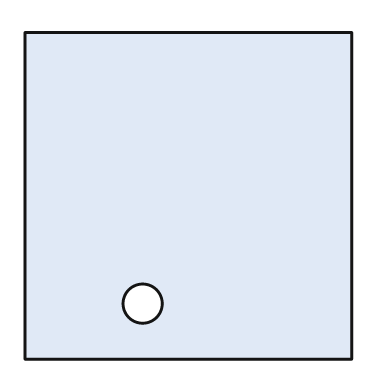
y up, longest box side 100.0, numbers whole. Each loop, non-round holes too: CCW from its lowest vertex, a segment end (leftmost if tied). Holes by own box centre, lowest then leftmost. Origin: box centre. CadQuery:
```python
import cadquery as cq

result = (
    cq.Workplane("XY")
    .moveTo(-50.0, -50.0)
    .lineTo(50.0, -50.0)
    .lineTo(50.0, 50.0)
    .lineTo(-50.0, 50.0)
    .close()
    .moveTo(-14.0, -33.0)
    .circle(6.0)
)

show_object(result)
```